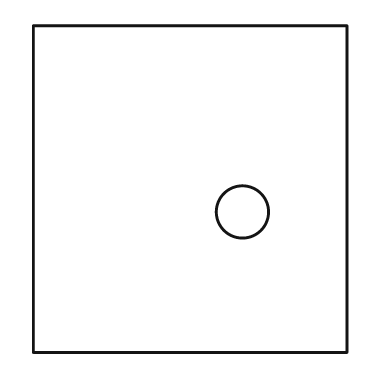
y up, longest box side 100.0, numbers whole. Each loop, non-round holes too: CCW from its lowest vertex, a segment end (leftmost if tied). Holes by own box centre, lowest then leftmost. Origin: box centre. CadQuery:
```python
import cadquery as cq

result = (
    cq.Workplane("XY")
    .moveTo(-48.0, -50.0)
    .lineTo(48.0, -50.0)
    .lineTo(48.0, 50.0)
    .lineTo(-48.0, 50.0)
    .close()
    .moveTo(16.0, -7.0)
    .circle(8.0)
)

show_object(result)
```